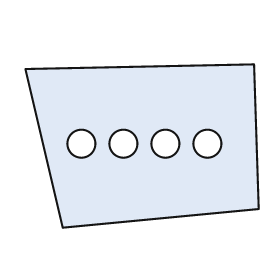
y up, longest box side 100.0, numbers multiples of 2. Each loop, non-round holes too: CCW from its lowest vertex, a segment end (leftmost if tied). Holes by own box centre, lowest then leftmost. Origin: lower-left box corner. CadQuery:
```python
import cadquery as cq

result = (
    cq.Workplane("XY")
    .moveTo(16.0, 0.0)
    .lineTo(100.0, 8.0)
    .lineTo(98.0, 70.0)
    .lineTo(0.0, 68.0)
    .close()
    .moveTo(24.0, 36.0)
    .circle(6.0)
    .moveTo(42.0, 36.0)
    .circle(6.0)
    .moveTo(60.0, 36.0)
    .circle(6.0)
    .moveTo(78.0, 36.0)
    .circle(6.0)
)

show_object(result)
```